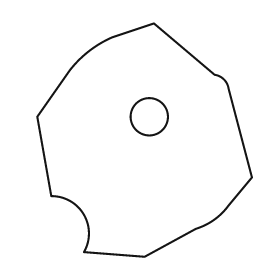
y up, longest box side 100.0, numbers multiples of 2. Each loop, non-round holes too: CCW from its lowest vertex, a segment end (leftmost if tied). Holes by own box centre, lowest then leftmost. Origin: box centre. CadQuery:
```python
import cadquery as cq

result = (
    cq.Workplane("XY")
    .moveTo(0.0, -50.0)
    .lineTo(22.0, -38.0)
    .threePointArc((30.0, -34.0), (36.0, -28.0))
    .lineTo(46.0, -16.0)
    .lineTo(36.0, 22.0)
    .threePointArc((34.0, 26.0), (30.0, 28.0))
    .lineTo(4.0, 50.0)
    .lineTo(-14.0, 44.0)
    .threePointArc((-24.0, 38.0), (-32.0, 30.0))
    .lineTo(-46.0, 10.0)
    .lineTo(-40.0, -24.0)
    .threePointArc((-26.0, -32.0), (-26.0, -48.0))
    .close()
    .moveTo(2.0, 10.0)
    .circle(8.0)
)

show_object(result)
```